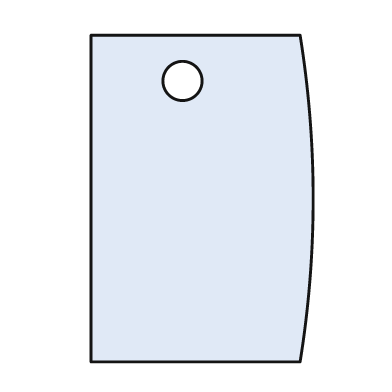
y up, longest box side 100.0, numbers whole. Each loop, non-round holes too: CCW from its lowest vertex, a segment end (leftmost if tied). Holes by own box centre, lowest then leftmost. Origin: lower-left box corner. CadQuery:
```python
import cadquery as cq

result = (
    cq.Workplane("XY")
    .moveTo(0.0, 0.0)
    .lineTo(64.0, 0.0)
    .threePointArc((68.0, 50.0), (64.0, 100.0))
    .lineTo(0.0, 100.0)
    .close()
    .moveTo(28.0, 86.0)
    .circle(6.0)
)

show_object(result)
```